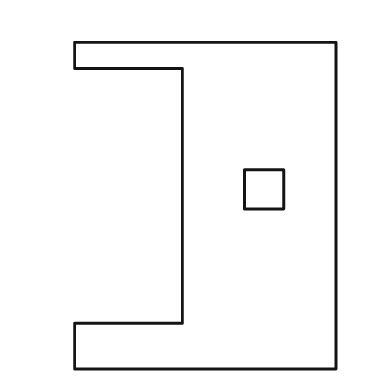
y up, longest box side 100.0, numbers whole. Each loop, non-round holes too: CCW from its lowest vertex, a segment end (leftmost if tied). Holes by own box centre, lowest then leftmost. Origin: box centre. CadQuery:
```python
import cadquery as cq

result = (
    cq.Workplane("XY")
    .moveTo(-40.0, -50.0)
    .lineTo(40.0, -50.0)
    .lineTo(40.0, 50.0)
    .lineTo(-40.0, 50.0)
    .lineTo(-40.0, 42.0)
    .lineTo(-7.0, 42.0)
    .lineTo(-7.0, -36.0)
    .lineTo(-40.0, -36.0)
    .close()
    .moveTo(12.0, -1.0)
    .lineTo(24.0, -1.0)
    .lineTo(24.0, 11.0)
    .lineTo(12.0, 11.0)
    .close()
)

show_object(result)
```